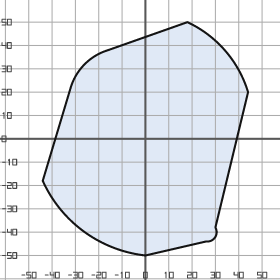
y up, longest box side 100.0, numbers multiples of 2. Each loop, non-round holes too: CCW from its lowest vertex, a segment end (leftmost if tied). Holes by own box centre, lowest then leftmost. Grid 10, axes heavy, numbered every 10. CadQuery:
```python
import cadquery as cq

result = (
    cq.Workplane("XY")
    .moveTo(0.0, -50.0)
    .lineTo(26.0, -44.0)
    .threePointArc((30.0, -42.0), (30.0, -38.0))
    .lineTo(44.0, 20.0)
    .threePointArc((34.0, 38.0), (18.0, 50.0))
    .lineTo(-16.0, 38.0)
    .threePointArc((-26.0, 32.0), (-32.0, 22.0))
    .lineTo(-44.0, -18.0)
    .threePointArc((-26.0, -40.0), (0.0, -50.0))
    .close()
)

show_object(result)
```